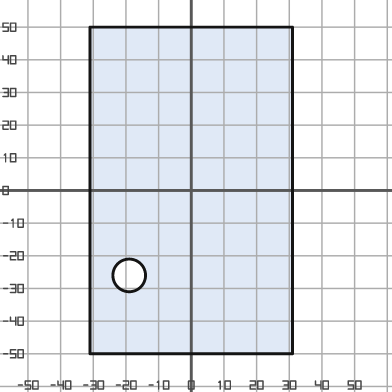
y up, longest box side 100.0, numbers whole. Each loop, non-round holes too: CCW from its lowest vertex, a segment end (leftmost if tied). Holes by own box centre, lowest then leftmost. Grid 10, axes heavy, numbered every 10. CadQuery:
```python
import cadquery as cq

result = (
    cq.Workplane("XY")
    .moveTo(-31.0, -50.0)
    .lineTo(31.0, -50.0)
    .lineTo(31.0, 50.0)
    .lineTo(-31.0, 50.0)
    .close()
    .moveTo(-19.0, -26.0)
    .circle(5.0)
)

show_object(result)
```